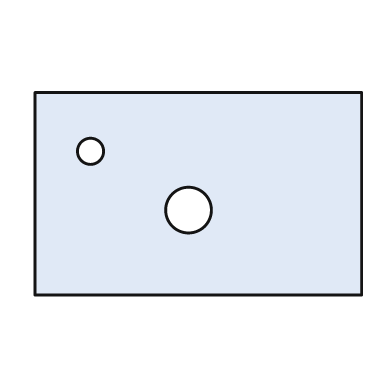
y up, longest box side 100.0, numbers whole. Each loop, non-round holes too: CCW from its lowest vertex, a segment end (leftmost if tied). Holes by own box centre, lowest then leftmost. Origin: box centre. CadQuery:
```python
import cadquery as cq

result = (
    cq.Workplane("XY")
    .moveTo(-50.0, -31.0)
    .lineTo(50.0, -31.0)
    .lineTo(50.0, 31.0)
    .lineTo(-50.0, 31.0)
    .close()
    .moveTo(-3.0, -5.0)
    .circle(7.0)
    .moveTo(-33.0, 13.0)
    .circle(4.0)
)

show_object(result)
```